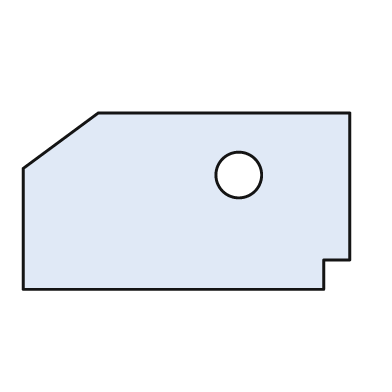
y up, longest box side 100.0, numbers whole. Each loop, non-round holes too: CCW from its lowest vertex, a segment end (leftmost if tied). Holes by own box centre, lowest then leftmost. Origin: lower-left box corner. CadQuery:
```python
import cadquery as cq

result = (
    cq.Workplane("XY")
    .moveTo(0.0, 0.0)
    .lineTo(92.0, 0.0)
    .lineTo(92.0, 9.0)
    .lineTo(100.0, 9.0)
    .lineTo(100.0, 54.0)
    .lineTo(23.0, 54.0)
    .lineTo(0.0, 37.0)
    .close()
    .moveTo(66.0, 35.0)
    .circle(7.0)
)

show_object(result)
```